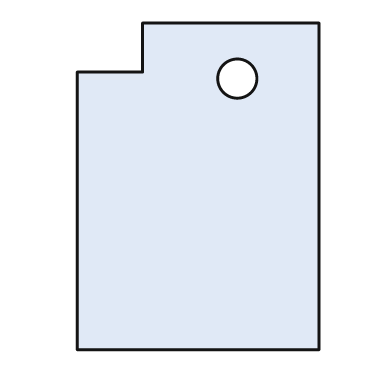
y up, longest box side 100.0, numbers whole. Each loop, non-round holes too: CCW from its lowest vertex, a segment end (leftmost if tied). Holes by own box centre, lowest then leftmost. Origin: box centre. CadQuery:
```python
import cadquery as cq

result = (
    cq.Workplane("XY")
    .moveTo(-37.0, -50.0)
    .lineTo(37.0, -50.0)
    .lineTo(37.0, 50.0)
    .lineTo(-17.0, 50.0)
    .lineTo(-17.0, 35.0)
    .lineTo(-37.0, 35.0)
    .close()
    .moveTo(12.0, 33.0)
    .circle(6.0)
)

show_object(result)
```